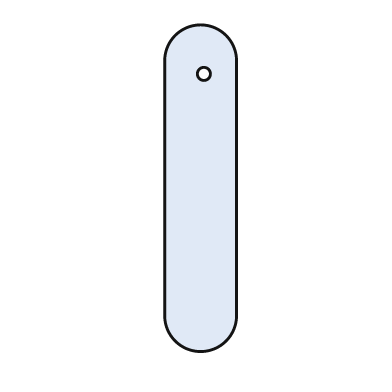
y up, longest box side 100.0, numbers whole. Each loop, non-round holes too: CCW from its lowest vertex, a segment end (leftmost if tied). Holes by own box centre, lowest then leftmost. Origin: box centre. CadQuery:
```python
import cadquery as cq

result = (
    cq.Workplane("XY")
    .moveTo(-11.0, -39.0)
    .threePointArc((0.0, -50.0), (11.0, -39.0))
    .lineTo(11.0, 39.0)
    .threePointArc((0.0, 50.0), (-11.0, 39.0))
    .close()
    .moveTo(1.0, 35.0)
    .circle(2.0)
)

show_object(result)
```